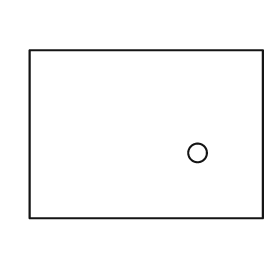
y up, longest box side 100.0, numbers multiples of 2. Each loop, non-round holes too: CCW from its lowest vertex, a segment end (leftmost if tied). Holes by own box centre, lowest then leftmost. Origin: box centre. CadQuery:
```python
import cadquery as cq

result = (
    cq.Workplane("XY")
    .moveTo(-50.0, -36.0)
    .lineTo(50.0, -36.0)
    .lineTo(50.0, 36.0)
    .lineTo(-50.0, 36.0)
    .close()
    .moveTo(22.0, -8.0)
    .circle(4.0)
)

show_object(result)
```